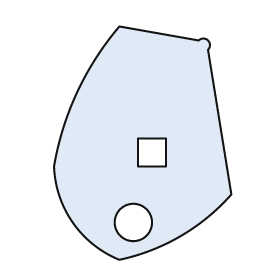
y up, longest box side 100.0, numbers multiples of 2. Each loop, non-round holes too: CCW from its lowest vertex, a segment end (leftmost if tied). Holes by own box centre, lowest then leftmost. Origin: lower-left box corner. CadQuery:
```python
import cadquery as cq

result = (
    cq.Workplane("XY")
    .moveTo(28.0, 0.0)
    .threePointArc((54.0, 10.0), (76.0, 28.0))
    .lineTo(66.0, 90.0)
    .threePointArc((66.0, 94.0), (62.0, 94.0))
    .lineTo(28.0, 100.0)
    .threePointArc((10.0, 72.0), (0.0, 40.0))
    .threePointArc((8.0, 16.0), (28.0, 0.0))
    .close()
    .moveTo(34.0, 16.0)
    .circle(8.0)
    .moveTo(36.0, 40.0)
    .lineTo(48.0, 40.0)
    .lineTo(48.0, 52.0)
    .lineTo(36.0, 52.0)
    .close()
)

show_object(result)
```